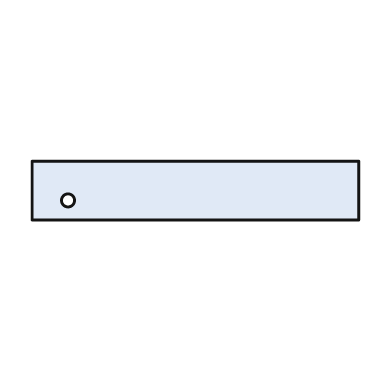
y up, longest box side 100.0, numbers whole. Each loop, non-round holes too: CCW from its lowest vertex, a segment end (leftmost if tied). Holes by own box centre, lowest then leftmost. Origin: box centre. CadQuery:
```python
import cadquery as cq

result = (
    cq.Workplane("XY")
    .moveTo(-50.0, -9.0)
    .lineTo(50.0, -9.0)
    .lineTo(50.0, 9.0)
    .lineTo(-50.0, 9.0)
    .close()
    .moveTo(-39.0, -3.0)
    .circle(2.0)
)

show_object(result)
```